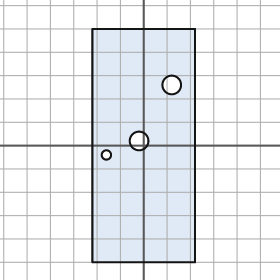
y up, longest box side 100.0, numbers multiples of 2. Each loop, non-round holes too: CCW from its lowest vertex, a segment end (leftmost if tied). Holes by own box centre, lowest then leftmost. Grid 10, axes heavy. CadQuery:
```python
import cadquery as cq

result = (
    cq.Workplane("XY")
    .moveTo(-22.0, -50.0)
    .lineTo(22.0, -50.0)
    .lineTo(22.0, 50.0)
    .lineTo(-22.0, 50.0)
    .close()
    .moveTo(-16.0, -4.0)
    .circle(2.0)
    .moveTo(-2.0, 2.0)
    .circle(4.0)
    .moveTo(12.0, 26.0)
    .circle(4.0)
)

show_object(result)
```